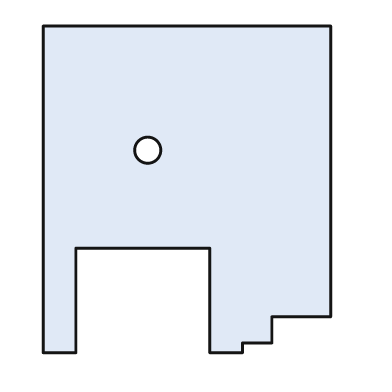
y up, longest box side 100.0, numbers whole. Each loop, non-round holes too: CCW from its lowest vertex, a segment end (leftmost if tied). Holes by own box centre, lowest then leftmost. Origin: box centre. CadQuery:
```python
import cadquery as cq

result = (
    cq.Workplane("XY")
    .moveTo(-44.0, -50.0)
    .lineTo(-34.0, -50.0)
    .lineTo(-34.0, -18.0)
    .lineTo(7.0, -18.0)
    .lineTo(7.0, -50.0)
    .lineTo(17.0, -50.0)
    .lineTo(17.0, -47.0)
    .lineTo(26.0, -47.0)
    .lineTo(26.0, -39.0)
    .lineTo(44.0, -39.0)
    .lineTo(44.0, 50.0)
    .lineTo(-44.0, 50.0)
    .close()
    .moveTo(-12.0, 12.0)
    .circle(4.0)
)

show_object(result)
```